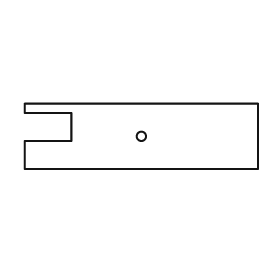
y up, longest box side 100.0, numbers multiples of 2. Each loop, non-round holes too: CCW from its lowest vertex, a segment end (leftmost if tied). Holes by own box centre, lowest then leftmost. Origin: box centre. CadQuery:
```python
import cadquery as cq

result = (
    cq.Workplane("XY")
    .moveTo(-50.0, -14.0)
    .lineTo(50.0, -14.0)
    .lineTo(50.0, 14.0)
    .lineTo(-50.0, 14.0)
    .lineTo(-50.0, 10.0)
    .lineTo(-30.0, 10.0)
    .lineTo(-30.0, -2.0)
    .lineTo(-50.0, -2.0)
    .close()
    .moveTo(0.0, 0.0)
    .circle(2.0)
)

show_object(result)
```